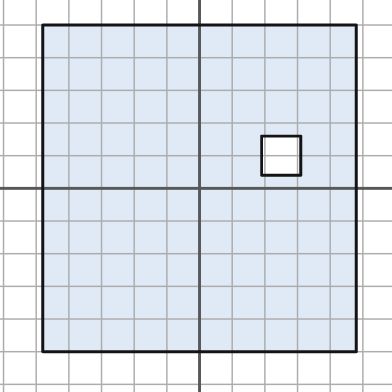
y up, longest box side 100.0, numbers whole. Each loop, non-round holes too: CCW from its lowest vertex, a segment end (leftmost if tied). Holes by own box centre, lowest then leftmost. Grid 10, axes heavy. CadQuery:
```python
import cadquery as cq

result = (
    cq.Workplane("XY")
    .moveTo(-48.0, -50.0)
    .lineTo(48.0, -50.0)
    .lineTo(48.0, 50.0)
    .lineTo(-48.0, 50.0)
    .close()
    .moveTo(19.0, 4.0)
    .lineTo(31.0, 4.0)
    .lineTo(31.0, 16.0)
    .lineTo(19.0, 16.0)
    .close()
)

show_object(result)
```